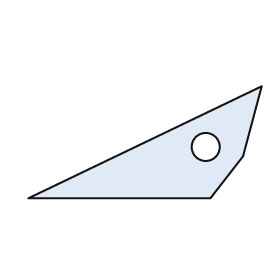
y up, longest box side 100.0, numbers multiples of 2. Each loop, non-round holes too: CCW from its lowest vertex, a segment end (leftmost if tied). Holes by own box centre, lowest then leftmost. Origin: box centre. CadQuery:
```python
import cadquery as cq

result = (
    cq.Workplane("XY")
    .moveTo(-50.0, -24.0)
    .lineTo(28.0, -24.0)
    .lineTo(42.0, -6.0)
    .lineTo(50.0, 24.0)
    .close()
    .moveTo(26.0, -2.0)
    .circle(6.0)
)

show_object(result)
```